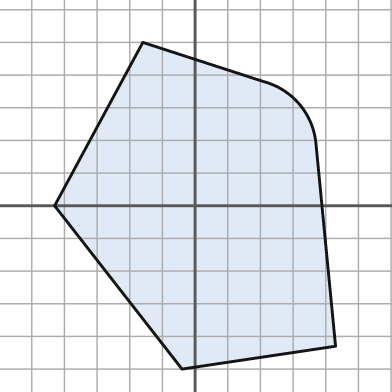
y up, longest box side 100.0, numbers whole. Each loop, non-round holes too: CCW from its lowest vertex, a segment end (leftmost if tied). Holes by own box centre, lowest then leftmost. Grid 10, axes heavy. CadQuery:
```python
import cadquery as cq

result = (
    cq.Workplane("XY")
    .moveTo(-4.0, -50.0)
    .lineTo(43.0, -43.0)
    .lineTo(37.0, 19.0)
    .threePointArc((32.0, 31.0), (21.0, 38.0))
    .lineTo(-16.0, 50.0)
    .lineTo(-43.0, 0.0)
    .close()
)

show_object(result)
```